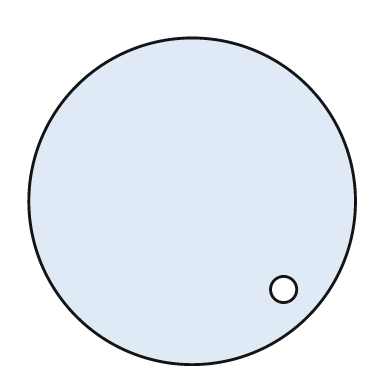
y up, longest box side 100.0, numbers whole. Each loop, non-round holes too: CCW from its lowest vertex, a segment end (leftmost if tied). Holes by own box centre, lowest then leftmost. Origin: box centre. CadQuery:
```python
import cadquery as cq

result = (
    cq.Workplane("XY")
    .moveTo(0.0, 0.0)
    .circle(50.0)
    .moveTo(28.0, -27.0)
    .circle(4.0)
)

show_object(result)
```